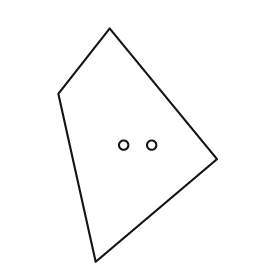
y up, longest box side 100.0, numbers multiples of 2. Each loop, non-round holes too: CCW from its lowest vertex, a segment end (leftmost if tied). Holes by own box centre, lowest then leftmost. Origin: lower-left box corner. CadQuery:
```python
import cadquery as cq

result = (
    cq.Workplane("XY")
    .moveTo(16.0, 0.0)
    .lineTo(68.0, 44.0)
    .lineTo(22.0, 100.0)
    .lineTo(0.0, 72.0)
    .close()
    .moveTo(28.0, 50.0)
    .circle(2.0)
    .moveTo(40.0, 50.0)
    .circle(2.0)
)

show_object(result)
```